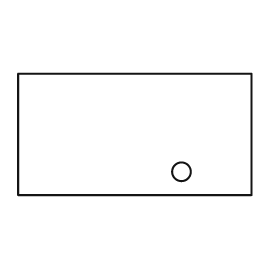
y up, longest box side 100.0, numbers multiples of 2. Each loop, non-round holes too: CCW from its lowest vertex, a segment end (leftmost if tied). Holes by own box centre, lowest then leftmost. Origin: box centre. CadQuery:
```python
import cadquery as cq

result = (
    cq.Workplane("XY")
    .moveTo(-50.0, -26.0)
    .lineTo(50.0, -26.0)
    .lineTo(50.0, 26.0)
    .lineTo(-50.0, 26.0)
    .close()
    .moveTo(20.0, -16.0)
    .circle(4.0)
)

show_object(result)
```